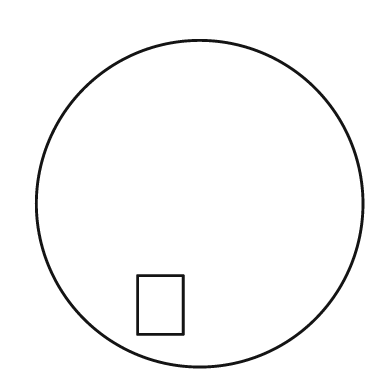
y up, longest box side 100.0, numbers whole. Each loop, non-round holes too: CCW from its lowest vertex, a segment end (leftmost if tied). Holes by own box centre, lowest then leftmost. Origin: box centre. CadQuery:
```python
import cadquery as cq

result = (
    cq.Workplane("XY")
    .moveTo(0.0, 0.0)
    .circle(50.0)
    .moveTo(-19.0, -40.0)
    .lineTo(-5.0, -40.0)
    .lineTo(-5.0, -22.0)
    .lineTo(-19.0, -22.0)
    .close()
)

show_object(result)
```